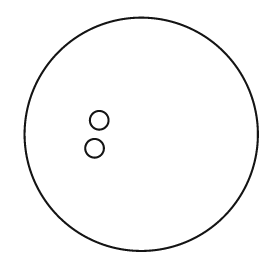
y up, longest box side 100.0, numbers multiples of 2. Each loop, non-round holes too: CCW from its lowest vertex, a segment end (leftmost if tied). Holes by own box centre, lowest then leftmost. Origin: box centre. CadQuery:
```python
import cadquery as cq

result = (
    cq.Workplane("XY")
    .moveTo(0.0, 0.0)
    .circle(50.0)
    .moveTo(-20.0, -6.0)
    .circle(4.0)
    .moveTo(-18.0, 6.0)
    .circle(4.0)
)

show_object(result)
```